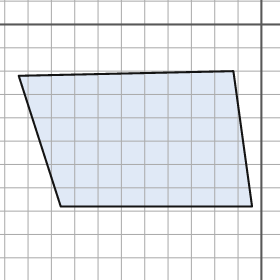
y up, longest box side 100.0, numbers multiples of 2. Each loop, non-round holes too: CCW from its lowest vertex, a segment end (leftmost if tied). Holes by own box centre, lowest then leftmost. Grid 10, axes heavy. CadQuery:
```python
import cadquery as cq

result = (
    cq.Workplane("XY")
    .moveTo(-86.0, -78.0)
    .lineTo(-4.0, -78.0)
    .lineTo(-12.0, -20.0)
    .lineTo(-104.0, -22.0)
    .close()
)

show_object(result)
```